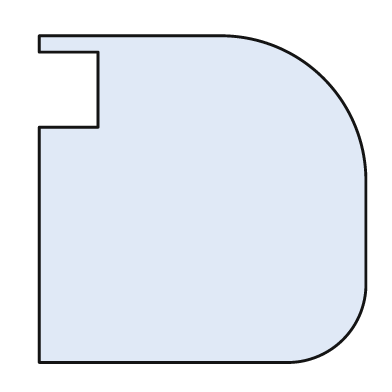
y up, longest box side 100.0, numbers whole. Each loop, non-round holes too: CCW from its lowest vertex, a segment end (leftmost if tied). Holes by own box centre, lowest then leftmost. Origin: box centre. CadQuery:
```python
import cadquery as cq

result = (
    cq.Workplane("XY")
    .moveTo(-50.0, -50.0)
    .lineTo(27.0, -50.0)
    .threePointArc((43.0, -43.0), (50.0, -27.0))
    .lineTo(50.0, 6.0)
    .threePointArc((37.0, 37.0), (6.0, 50.0))
    .lineTo(-50.0, 50.0)
    .lineTo(-50.0, 45.0)
    .lineTo(-32.0, 45.0)
    .lineTo(-32.0, 22.0)
    .lineTo(-50.0, 22.0)
    .close()
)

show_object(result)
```